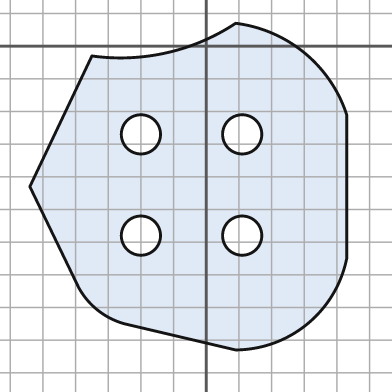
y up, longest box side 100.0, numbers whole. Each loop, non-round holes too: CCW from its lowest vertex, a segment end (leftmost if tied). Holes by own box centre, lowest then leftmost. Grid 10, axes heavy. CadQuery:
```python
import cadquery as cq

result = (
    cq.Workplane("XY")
    .moveTo(9.0, -93.0)
    .threePointArc((31.0, -85.0), (43.0, -65.0))
    .lineTo(43.0, -21.0)
    .threePointArc((30.0, -2.0), (9.0, 7.0))
    .threePointArc((-12.0, -2.0), (-35.0, -3.0))
    .lineTo(-54.0, -43.0)
    .lineTo(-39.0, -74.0)
    .threePointArc((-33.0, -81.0), (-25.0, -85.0))
    .close()
    .moveTo(-20.0, -58.0)
    .circle(6.0)
    .moveTo(11.0, -58.0)
    .circle(6.0)
    .moveTo(-20.0, -27.0)
    .circle(6.0)
    .moveTo(11.0, -27.0)
    .circle(6.0)
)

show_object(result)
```